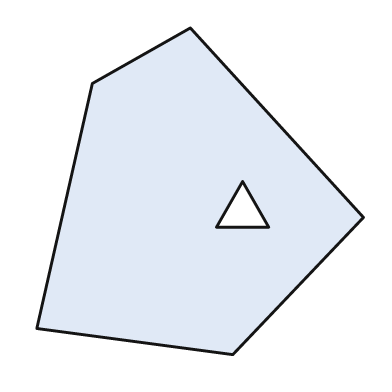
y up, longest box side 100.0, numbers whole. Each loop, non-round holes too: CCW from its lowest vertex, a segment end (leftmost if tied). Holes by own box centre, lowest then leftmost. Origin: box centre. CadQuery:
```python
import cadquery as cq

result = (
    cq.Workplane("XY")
    .moveTo(10.0, -50.0)
    .lineTo(50.0, -8.0)
    .lineTo(-3.0, 50.0)
    .lineTo(-33.0, 33.0)
    .lineTo(-50.0, -42.0)
    .close()
    .moveTo(5.0, -11.0)
    .lineTo(21.0, -11.0)
    .lineTo(13.0, 3.0)
    .close()
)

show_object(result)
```